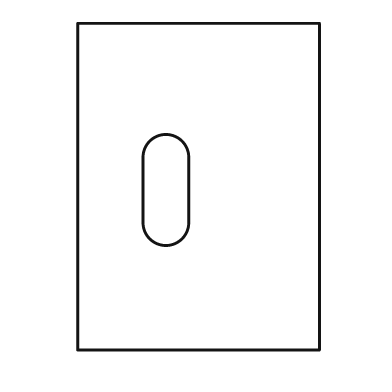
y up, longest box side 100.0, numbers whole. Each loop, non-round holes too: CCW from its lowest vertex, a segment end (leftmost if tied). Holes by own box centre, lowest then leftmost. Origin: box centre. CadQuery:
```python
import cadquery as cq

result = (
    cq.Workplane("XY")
    .moveTo(-37.0, -50.0)
    .lineTo(37.0, -50.0)
    .lineTo(37.0, 50.0)
    .lineTo(-37.0, 50.0)
    .close()
    .moveTo(-17.0, -11.0)
    .threePointArc((-10.0, -18.0), (-3.0, -11.0))
    .lineTo(-3.0, 9.0)
    .threePointArc((-10.0, 16.0), (-17.0, 9.0))
    .close()
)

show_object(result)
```